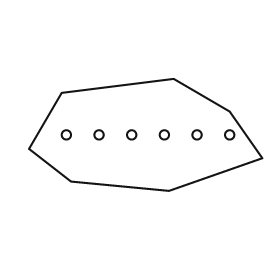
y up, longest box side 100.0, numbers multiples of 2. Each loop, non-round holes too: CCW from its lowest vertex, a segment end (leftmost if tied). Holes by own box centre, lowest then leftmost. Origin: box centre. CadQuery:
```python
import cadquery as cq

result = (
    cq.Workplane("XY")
    .moveTo(10.0, -24.0)
    .lineTo(50.0, -10.0)
    .lineTo(36.0, 10.0)
    .lineTo(12.0, 24.0)
    .lineTo(-36.0, 18.0)
    .lineTo(-50.0, -6.0)
    .lineTo(-32.0, -20.0)
    .close()
    .moveTo(-34.0, 0.0)
    .circle(2.0)
    .moveTo(-20.0, 0.0)
    .circle(2.0)
    .moveTo(-6.0, 0.0)
    .circle(2.0)
    .moveTo(8.0, 0.0)
    .circle(2.0)
    .moveTo(22.0, 0.0)
    .circle(2.0)
    .moveTo(36.0, 0.0)
    .circle(2.0)
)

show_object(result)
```